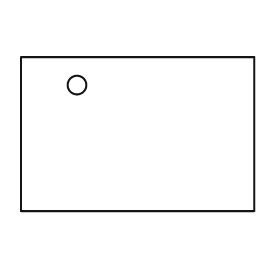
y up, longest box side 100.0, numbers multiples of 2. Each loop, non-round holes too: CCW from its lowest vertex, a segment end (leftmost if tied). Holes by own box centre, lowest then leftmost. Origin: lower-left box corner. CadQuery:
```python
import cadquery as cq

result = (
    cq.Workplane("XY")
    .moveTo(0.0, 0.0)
    .lineTo(100.0, 0.0)
    .lineTo(100.0, 66.0)
    .lineTo(0.0, 66.0)
    .close()
    .moveTo(24.0, 54.0)
    .circle(4.0)
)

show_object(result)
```